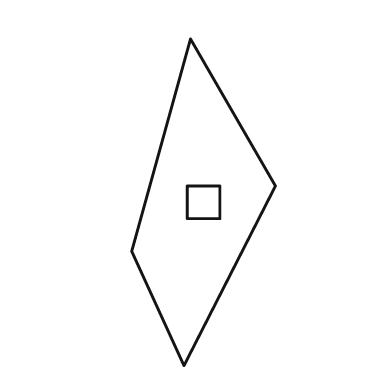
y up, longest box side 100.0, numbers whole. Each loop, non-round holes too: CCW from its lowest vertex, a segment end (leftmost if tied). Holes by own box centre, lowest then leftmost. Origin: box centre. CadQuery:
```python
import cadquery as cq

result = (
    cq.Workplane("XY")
    .moveTo(-6.0, -50.0)
    .lineTo(22.0, 5.0)
    .lineTo(-4.0, 50.0)
    .lineTo(-22.0, -15.0)
    .close()
    .moveTo(-5.0, -5.0)
    .lineTo(5.0, -5.0)
    .lineTo(5.0, 5.0)
    .lineTo(-5.0, 5.0)
    .close()
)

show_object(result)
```